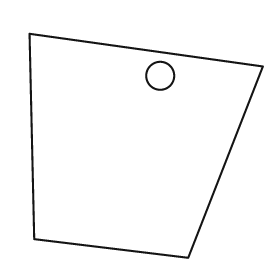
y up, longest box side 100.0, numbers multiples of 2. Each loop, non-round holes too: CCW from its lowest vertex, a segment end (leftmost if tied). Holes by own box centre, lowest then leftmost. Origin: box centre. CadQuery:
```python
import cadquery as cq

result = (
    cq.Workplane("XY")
    .moveTo(18.0, -48.0)
    .lineTo(50.0, 34.0)
    .lineTo(-50.0, 48.0)
    .lineTo(-48.0, -40.0)
    .close()
    .moveTo(6.0, 30.0)
    .circle(6.0)
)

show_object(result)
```